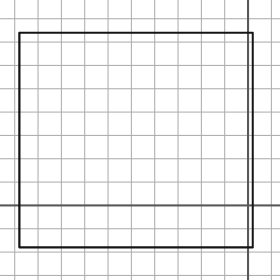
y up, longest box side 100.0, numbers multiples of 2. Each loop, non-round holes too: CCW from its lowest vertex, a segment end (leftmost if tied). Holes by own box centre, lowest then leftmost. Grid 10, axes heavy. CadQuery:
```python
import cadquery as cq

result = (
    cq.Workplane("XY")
    .moveTo(-98.0, -18.0)
    .lineTo(2.0, -18.0)
    .lineTo(2.0, 74.0)
    .lineTo(-98.0, 74.0)
    .close()
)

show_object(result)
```